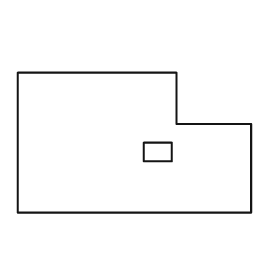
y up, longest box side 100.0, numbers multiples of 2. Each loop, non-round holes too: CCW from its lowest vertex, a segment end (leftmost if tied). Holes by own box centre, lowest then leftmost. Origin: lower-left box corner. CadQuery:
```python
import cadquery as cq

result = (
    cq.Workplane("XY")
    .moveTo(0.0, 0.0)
    .lineTo(100.0, 0.0)
    .lineTo(100.0, 38.0)
    .lineTo(68.0, 38.0)
    .lineTo(68.0, 60.0)
    .lineTo(0.0, 60.0)
    .close()
    .moveTo(54.0, 22.0)
    .lineTo(66.0, 22.0)
    .lineTo(66.0, 30.0)
    .lineTo(54.0, 30.0)
    .close()
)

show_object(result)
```